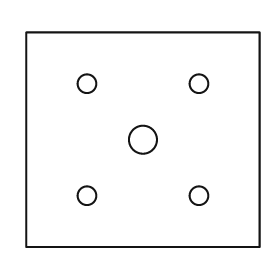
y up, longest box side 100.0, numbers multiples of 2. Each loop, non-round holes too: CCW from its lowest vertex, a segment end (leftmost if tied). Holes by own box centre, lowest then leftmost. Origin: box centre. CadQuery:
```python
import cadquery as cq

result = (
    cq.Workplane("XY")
    .moveTo(-50.0, -46.0)
    .lineTo(50.0, -46.0)
    .lineTo(50.0, 46.0)
    .lineTo(-50.0, 46.0)
    .close()
    .moveTo(-24.0, -24.0)
    .circle(4.0)
    .moveTo(24.0, -24.0)
    .circle(4.0)
    .moveTo(0.0, 0.0)
    .circle(6.0)
    .moveTo(-24.0, 24.0)
    .circle(4.0)
    .moveTo(24.0, 24.0)
    .circle(4.0)
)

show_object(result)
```